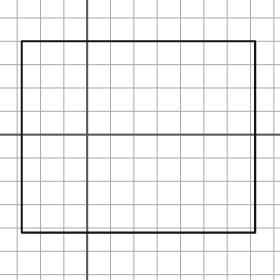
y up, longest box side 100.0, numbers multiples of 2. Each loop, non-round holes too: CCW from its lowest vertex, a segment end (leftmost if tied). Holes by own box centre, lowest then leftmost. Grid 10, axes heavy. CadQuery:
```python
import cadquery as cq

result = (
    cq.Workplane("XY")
    .moveTo(-28.0, -42.0)
    .lineTo(72.0, -42.0)
    .lineTo(72.0, 40.0)
    .lineTo(-28.0, 40.0)
    .close()
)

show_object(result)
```